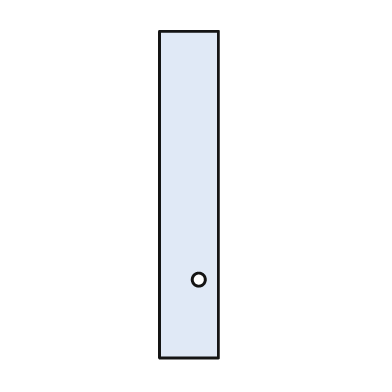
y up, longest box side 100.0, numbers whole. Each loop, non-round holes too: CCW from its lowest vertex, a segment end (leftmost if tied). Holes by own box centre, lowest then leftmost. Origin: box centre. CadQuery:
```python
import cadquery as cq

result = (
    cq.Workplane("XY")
    .moveTo(-9.0, -50.0)
    .lineTo(9.0, -50.0)
    .lineTo(9.0, 50.0)
    .lineTo(-9.0, 50.0)
    .close()
    .moveTo(3.0, -26.0)
    .circle(2.0)
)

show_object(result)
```